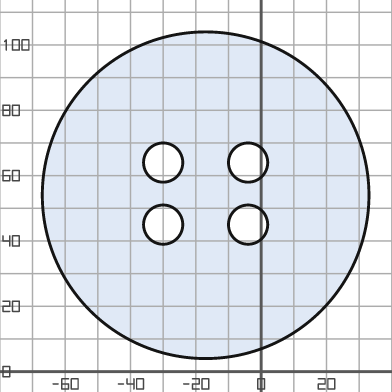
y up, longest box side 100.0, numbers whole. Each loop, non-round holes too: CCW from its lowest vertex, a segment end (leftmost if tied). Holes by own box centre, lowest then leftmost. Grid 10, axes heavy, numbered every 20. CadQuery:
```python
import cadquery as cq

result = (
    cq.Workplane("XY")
    .moveTo(-17.0, 54.0)
    .circle(50.0)
    .moveTo(-30.0, 45.0)
    .circle(6.0)
    .moveTo(-4.0, 45.0)
    .circle(6.0)
    .moveTo(-30.0, 64.0)
    .circle(6.0)
    .moveTo(-4.0, 64.0)
    .circle(6.0)
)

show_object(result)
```